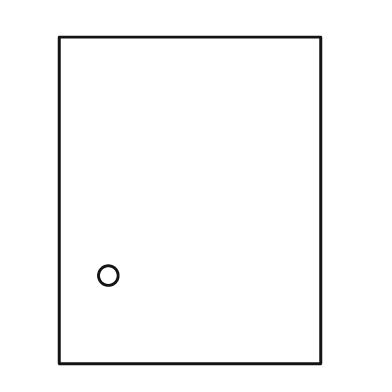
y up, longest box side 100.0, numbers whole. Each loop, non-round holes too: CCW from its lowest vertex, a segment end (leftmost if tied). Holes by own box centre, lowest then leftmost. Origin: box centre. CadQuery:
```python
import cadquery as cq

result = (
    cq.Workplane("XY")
    .moveTo(-40.0, -50.0)
    .lineTo(40.0, -50.0)
    .lineTo(40.0, 50.0)
    .lineTo(-40.0, 50.0)
    .close()
    .moveTo(-25.0, -23.0)
    .circle(3.0)
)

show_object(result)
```